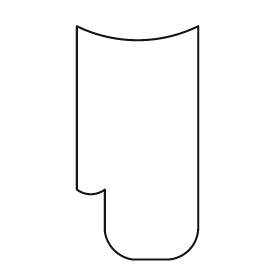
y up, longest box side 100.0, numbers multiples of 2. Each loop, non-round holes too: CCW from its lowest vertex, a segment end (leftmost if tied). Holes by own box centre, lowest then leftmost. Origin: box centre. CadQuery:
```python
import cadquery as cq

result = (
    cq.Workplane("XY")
    .moveTo(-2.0, -50.0)
    .lineTo(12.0, -50.0)
    .threePointArc((22.0, -46.0), (26.0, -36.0))
    .lineTo(26.0, 50.0)
    .threePointArc((0.0, 44.0), (-26.0, 50.0))
    .lineTo(-26.0, -20.0)
    .threePointArc((-20.0, -22.0), (-14.0, -20.0))
    .lineTo(-14.0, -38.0)
    .threePointArc((-10.0, -46.0), (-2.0, -50.0))
    .close()
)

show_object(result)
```